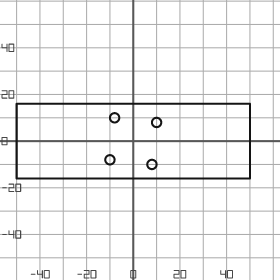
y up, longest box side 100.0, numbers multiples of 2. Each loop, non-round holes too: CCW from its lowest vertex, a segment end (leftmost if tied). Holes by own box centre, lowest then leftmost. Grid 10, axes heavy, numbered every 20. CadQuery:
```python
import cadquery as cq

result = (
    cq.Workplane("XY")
    .moveTo(-50.0, -16.0)
    .lineTo(50.0, -16.0)
    .lineTo(50.0, 16.0)
    .lineTo(-50.0, 16.0)
    .close()
    .moveTo(8.0, -10.0)
    .circle(2.0)
    .moveTo(-10.0, -8.0)
    .circle(2.0)
    .moveTo(10.0, 8.0)
    .circle(2.0)
    .moveTo(-8.0, 10.0)
    .circle(2.0)
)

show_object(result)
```